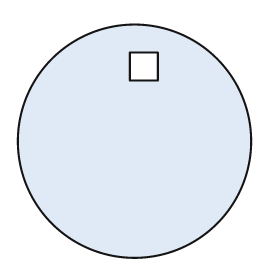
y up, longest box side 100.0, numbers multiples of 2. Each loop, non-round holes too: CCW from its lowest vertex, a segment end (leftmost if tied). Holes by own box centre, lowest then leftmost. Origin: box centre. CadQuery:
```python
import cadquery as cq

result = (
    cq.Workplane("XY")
    .moveTo(0.0, 0.0)
    .circle(50.0)
    .moveTo(-2.0, 26.0)
    .lineTo(10.0, 26.0)
    .lineTo(10.0, 38.0)
    .lineTo(-2.0, 38.0)
    .close()
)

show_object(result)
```